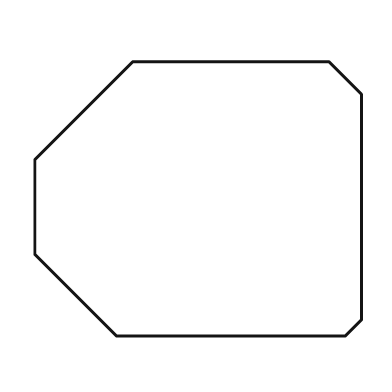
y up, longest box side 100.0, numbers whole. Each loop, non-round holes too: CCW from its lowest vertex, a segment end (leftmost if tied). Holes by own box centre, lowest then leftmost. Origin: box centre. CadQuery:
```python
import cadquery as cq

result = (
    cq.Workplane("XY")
    .moveTo(-25.0, -42.0)
    .lineTo(45.0, -42.0)
    .lineTo(50.0, -37.0)
    .lineTo(50.0, 32.0)
    .lineTo(40.0, 42.0)
    .lineTo(-20.0, 42.0)
    .lineTo(-50.0, 12.0)
    .lineTo(-50.0, -17.0)
    .close()
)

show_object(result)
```